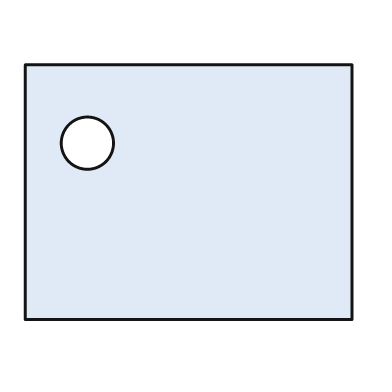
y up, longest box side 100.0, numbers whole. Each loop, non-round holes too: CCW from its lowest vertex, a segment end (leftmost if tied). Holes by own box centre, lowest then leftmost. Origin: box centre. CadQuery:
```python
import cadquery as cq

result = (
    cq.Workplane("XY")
    .moveTo(-50.0, -39.0)
    .lineTo(50.0, -39.0)
    .lineTo(50.0, 39.0)
    .lineTo(-50.0, 39.0)
    .close()
    .moveTo(-31.0, 15.0)
    .circle(8.0)
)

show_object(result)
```